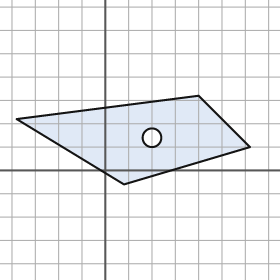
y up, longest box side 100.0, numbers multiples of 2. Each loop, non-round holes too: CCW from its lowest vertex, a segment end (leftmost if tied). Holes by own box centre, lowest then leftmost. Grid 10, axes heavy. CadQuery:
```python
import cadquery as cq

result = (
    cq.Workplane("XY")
    .moveTo(8.0, -6.0)
    .lineTo(62.0, 10.0)
    .lineTo(40.0, 32.0)
    .lineTo(-38.0, 22.0)
    .close()
    .moveTo(20.0, 14.0)
    .circle(4.0)
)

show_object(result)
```